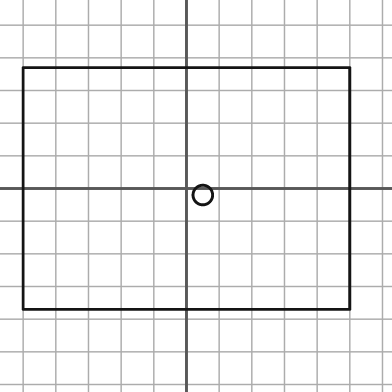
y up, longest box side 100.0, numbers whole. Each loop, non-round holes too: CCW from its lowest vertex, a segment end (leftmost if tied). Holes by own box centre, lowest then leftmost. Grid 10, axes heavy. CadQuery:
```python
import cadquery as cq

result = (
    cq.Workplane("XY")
    .moveTo(-50.0, -37.0)
    .lineTo(50.0, -37.0)
    .lineTo(50.0, 37.0)
    .lineTo(-50.0, 37.0)
    .close()
    .moveTo(5.0, -2.0)
    .circle(3.0)
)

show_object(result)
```